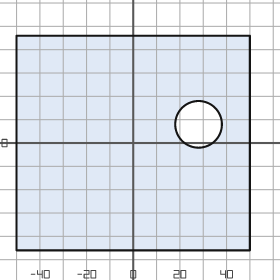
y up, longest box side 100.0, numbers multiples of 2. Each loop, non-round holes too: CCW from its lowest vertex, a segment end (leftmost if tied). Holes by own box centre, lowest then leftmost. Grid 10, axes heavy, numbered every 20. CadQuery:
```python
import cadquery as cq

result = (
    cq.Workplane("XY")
    .moveTo(-50.0, -46.0)
    .lineTo(50.0, -46.0)
    .lineTo(50.0, 46.0)
    .lineTo(-50.0, 46.0)
    .close()
    .moveTo(28.0, 8.0)
    .circle(10.0)
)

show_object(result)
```